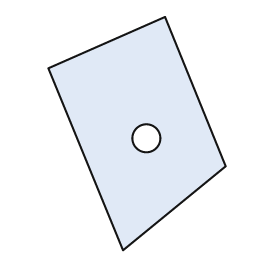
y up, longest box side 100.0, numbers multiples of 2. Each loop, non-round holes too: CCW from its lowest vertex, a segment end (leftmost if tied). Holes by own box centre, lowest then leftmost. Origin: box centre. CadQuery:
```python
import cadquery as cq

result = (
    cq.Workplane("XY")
    .moveTo(-6.0, -50.0)
    .lineTo(38.0, -14.0)
    .lineTo(12.0, 50.0)
    .lineTo(-38.0, 28.0)
    .close()
    .moveTo(4.0, -2.0)
    .circle(6.0)
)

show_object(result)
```